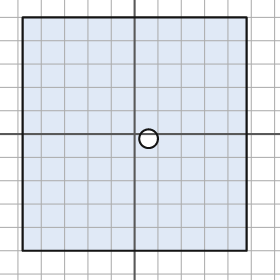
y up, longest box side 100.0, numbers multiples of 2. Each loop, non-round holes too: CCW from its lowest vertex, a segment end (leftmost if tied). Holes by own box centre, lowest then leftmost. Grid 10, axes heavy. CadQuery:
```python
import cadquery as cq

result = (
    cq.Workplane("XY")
    .moveTo(-48.0, -50.0)
    .lineTo(48.0, -50.0)
    .lineTo(48.0, 50.0)
    .lineTo(-48.0, 50.0)
    .close()
    .moveTo(6.0, -2.0)
    .circle(4.0)
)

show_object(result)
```